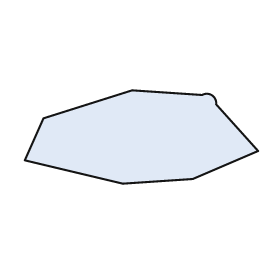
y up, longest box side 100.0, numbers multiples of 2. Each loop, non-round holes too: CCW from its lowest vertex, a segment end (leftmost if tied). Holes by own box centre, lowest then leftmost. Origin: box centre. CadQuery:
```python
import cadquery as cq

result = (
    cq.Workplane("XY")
    .moveTo(-8.0, -20.0)
    .lineTo(22.0, -18.0)
    .lineTo(50.0, -6.0)
    .lineTo(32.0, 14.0)
    .threePointArc((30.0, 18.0), (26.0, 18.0))
    .lineTo(-4.0, 20.0)
    .lineTo(-42.0, 8.0)
    .lineTo(-50.0, -10.0)
    .close()
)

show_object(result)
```